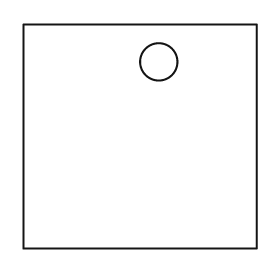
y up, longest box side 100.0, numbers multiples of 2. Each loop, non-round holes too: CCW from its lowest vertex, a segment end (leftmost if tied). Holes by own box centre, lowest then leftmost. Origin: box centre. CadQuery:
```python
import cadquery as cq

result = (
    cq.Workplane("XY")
    .moveTo(-50.0, -48.0)
    .lineTo(50.0, -48.0)
    .lineTo(50.0, 48.0)
    .lineTo(-50.0, 48.0)
    .close()
    .moveTo(8.0, 32.0)
    .circle(8.0)
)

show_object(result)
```